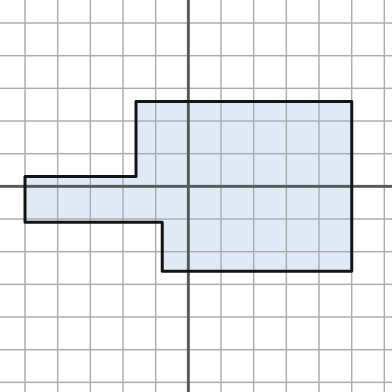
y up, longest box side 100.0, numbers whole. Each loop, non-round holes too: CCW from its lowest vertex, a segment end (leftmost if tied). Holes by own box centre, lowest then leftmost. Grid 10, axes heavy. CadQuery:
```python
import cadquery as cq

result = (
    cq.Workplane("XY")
    .moveTo(-8.0, -26.0)
    .lineTo(50.0, -26.0)
    .lineTo(50.0, 26.0)
    .lineTo(-16.0, 26.0)
    .lineTo(-16.0, 3.0)
    .lineTo(-50.0, 3.0)
    .lineTo(-50.0, -11.0)
    .lineTo(-8.0, -11.0)
    .close()
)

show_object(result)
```